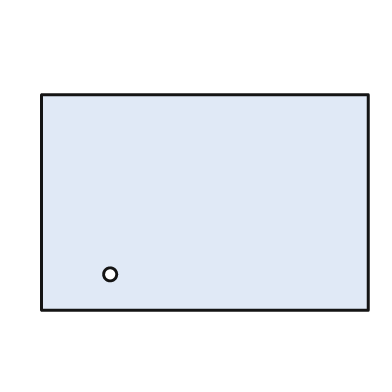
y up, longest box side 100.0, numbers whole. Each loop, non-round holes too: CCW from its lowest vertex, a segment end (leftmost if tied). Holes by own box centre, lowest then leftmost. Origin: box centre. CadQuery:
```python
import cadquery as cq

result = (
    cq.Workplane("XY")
    .moveTo(-50.0, -33.0)
    .lineTo(50.0, -33.0)
    .lineTo(50.0, 33.0)
    .lineTo(-50.0, 33.0)
    .close()
    .moveTo(-29.0, -22.0)
    .circle(2.0)
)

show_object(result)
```